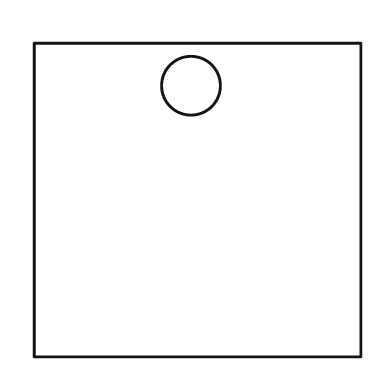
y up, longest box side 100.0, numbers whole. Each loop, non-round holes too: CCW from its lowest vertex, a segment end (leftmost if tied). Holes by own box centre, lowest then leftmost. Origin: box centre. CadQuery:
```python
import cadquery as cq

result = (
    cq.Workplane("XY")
    .moveTo(-50.0, -48.0)
    .lineTo(50.0, -48.0)
    .lineTo(50.0, 48.0)
    .lineTo(-50.0, 48.0)
    .close()
    .moveTo(-2.0, 35.0)
    .circle(9.0)
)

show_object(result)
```